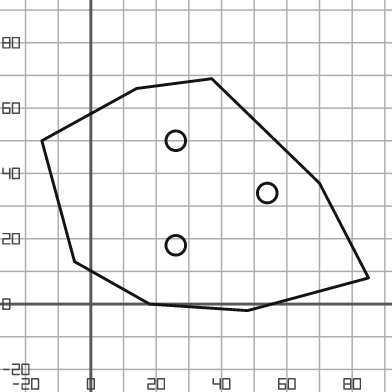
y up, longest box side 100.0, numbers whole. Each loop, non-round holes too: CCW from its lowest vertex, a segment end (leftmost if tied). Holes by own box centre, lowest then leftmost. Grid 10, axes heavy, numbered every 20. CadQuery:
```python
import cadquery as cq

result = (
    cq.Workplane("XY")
    .moveTo(48.0, -2.0)
    .lineTo(85.0, 8.0)
    .lineTo(70.0, 37.0)
    .lineTo(37.0, 69.0)
    .lineTo(14.0, 66.0)
    .lineTo(-15.0, 50.0)
    .lineTo(-5.0, 13.0)
    .lineTo(18.0, 0.0)
    .close()
    .moveTo(26.0, 18.0)
    .circle(3.0)
    .moveTo(54.0, 34.0)
    .circle(3.0)
    .moveTo(26.0, 50.0)
    .circle(3.0)
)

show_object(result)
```